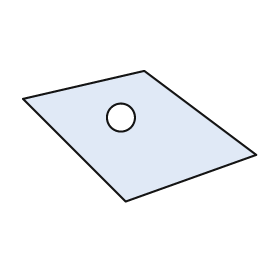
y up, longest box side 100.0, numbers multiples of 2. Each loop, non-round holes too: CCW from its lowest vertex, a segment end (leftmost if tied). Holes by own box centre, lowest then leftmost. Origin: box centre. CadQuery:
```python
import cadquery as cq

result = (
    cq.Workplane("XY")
    .moveTo(-6.0, -28.0)
    .lineTo(50.0, -8.0)
    .lineTo(2.0, 28.0)
    .lineTo(-50.0, 16.0)
    .close()
    .moveTo(-8.0, 8.0)
    .circle(6.0)
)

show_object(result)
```